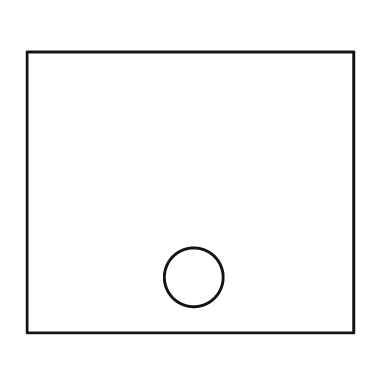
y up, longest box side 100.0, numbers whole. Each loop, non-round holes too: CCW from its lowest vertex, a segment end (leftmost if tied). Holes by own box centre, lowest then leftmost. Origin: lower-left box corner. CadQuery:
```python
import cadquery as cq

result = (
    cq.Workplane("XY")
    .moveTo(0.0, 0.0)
    .lineTo(100.0, 0.0)
    .lineTo(100.0, 86.0)
    .lineTo(0.0, 86.0)
    .close()
    .moveTo(51.0, 17.0)
    .circle(9.0)
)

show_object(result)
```